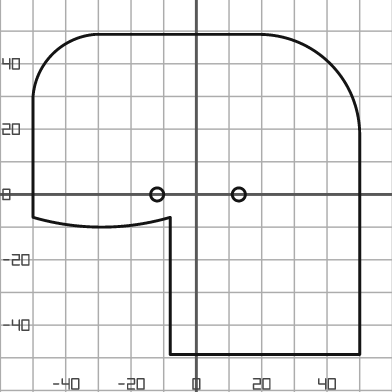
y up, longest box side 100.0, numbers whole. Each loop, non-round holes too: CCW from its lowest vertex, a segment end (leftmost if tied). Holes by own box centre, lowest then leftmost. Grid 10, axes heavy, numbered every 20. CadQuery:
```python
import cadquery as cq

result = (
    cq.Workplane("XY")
    .moveTo(-8.0, -49.0)
    .lineTo(50.0, -49.0)
    .lineTo(50.0, 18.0)
    .threePointArc((41.0, 40.0), (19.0, 49.0))
    .lineTo(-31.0, 49.0)
    .threePointArc((-44.0, 43.0), (-50.0, 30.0))
    .lineTo(-50.0, -7.0)
    .threePointArc((-29.0, -10.0), (-8.0, -7.0))
    .close()
    .moveTo(-12.0, 0.0)
    .circle(2.0)
    .moveTo(13.0, 0.0)
    .circle(2.0)
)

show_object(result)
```